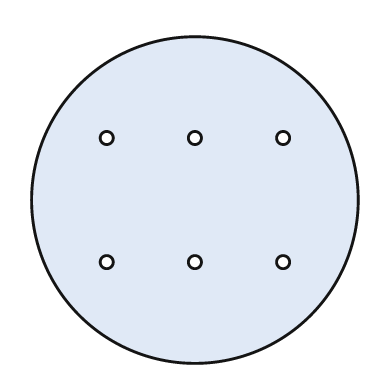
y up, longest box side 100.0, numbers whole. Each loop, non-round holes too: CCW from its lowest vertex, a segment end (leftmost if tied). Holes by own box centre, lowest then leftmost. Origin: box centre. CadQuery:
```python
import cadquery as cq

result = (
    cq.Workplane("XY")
    .moveTo(0.0, 0.0)
    .circle(50.0)
    .moveTo(-27.0, -19.0)
    .circle(2.0)
    .moveTo(0.0, -19.0)
    .circle(2.0)
    .moveTo(27.0, -19.0)
    .circle(2.0)
    .moveTo(-27.0, 19.0)
    .circle(2.0)
    .moveTo(0.0, 19.0)
    .circle(2.0)
    .moveTo(27.0, 19.0)
    .circle(2.0)
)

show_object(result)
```